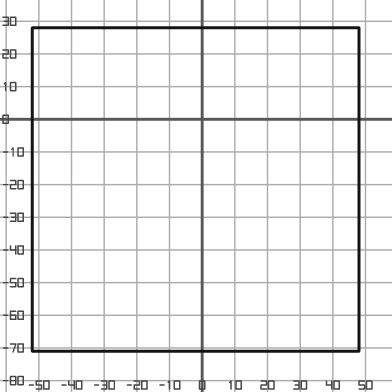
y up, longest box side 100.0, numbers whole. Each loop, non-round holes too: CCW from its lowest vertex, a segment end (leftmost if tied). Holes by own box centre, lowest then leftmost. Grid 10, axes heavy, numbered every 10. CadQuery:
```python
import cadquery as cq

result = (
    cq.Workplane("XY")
    .moveTo(-52.0, -71.0)
    .lineTo(48.0, -71.0)
    .lineTo(48.0, 28.0)
    .lineTo(-52.0, 28.0)
    .close()
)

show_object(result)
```